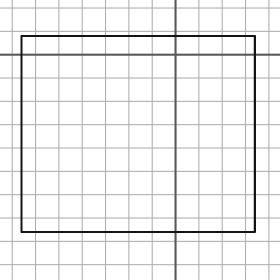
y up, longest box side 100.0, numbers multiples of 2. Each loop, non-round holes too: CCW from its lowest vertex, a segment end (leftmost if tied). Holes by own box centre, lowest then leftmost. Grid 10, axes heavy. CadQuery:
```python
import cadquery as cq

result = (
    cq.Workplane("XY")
    .moveTo(-66.0, -76.0)
    .lineTo(34.0, -76.0)
    .lineTo(34.0, 8.0)
    .lineTo(-66.0, 8.0)
    .close()
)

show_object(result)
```